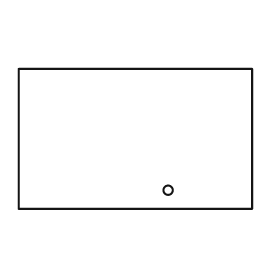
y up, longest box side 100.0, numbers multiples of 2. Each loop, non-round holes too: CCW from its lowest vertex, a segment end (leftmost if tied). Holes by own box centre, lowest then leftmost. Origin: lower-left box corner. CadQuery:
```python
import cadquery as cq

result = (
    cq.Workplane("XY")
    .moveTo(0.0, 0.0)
    .lineTo(100.0, 0.0)
    .lineTo(100.0, 60.0)
    .lineTo(0.0, 60.0)
    .close()
    .moveTo(64.0, 8.0)
    .circle(2.0)
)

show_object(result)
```